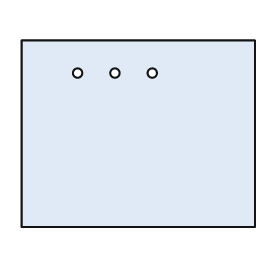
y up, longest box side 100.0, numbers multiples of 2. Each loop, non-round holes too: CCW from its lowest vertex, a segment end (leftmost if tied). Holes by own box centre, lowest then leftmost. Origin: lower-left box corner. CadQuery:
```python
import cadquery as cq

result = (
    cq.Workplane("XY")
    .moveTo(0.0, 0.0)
    .lineTo(100.0, 0.0)
    .lineTo(100.0, 80.0)
    .lineTo(0.0, 80.0)
    .close()
    .moveTo(24.0, 66.0)
    .circle(2.0)
    .moveTo(40.0, 66.0)
    .circle(2.0)
    .moveTo(56.0, 66.0)
    .circle(2.0)
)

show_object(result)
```